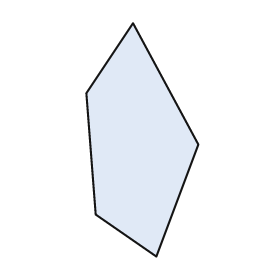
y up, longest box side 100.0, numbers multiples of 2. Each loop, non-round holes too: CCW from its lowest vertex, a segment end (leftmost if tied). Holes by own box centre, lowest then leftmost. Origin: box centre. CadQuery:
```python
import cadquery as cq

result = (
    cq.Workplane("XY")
    .moveTo(6.0, -50.0)
    .lineTo(24.0, -2.0)
    .lineTo(-4.0, 50.0)
    .lineTo(-24.0, 20.0)
    .lineTo(-20.0, -32.0)
    .close()
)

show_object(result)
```